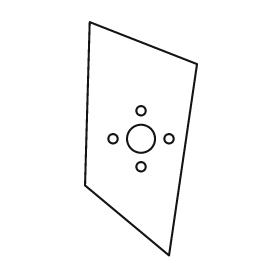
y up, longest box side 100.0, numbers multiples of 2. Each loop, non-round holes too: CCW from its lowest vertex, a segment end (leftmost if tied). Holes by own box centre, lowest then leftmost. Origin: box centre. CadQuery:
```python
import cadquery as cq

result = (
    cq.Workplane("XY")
    .moveTo(12.0, -50.0)
    .lineTo(24.0, 32.0)
    .lineTo(-22.0, 50.0)
    .lineTo(-24.0, -20.0)
    .close()
    .moveTo(0.0, -12.0)
    .circle(2.0)
    .moveTo(-12.0, 0.0)
    .circle(2.0)
    .moveTo(0.0, 0.0)
    .circle(6.0)
    .moveTo(12.0, 0.0)
    .circle(2.0)
    .moveTo(0.0, 12.0)
    .circle(2.0)
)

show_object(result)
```